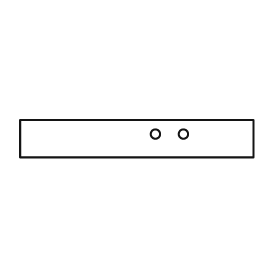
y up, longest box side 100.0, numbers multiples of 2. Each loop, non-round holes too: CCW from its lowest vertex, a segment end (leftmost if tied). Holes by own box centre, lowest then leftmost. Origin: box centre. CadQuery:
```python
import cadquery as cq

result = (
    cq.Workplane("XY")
    .moveTo(-50.0, -8.0)
    .lineTo(50.0, -8.0)
    .lineTo(50.0, 8.0)
    .lineTo(-50.0, 8.0)
    .close()
    .moveTo(8.0, 2.0)
    .circle(2.0)
    .moveTo(20.0, 2.0)
    .circle(2.0)
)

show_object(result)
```